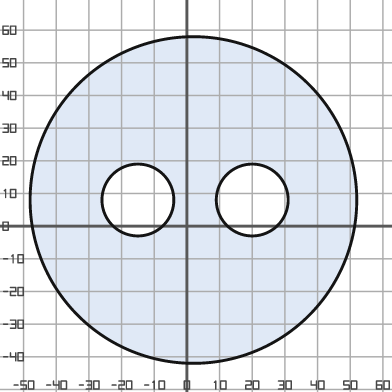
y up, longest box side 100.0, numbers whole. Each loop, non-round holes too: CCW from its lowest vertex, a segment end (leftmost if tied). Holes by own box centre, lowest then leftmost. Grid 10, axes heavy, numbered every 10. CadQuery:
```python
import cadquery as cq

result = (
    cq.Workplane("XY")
    .moveTo(2.0, 8.0)
    .circle(50.0)
    .moveTo(-15.0, 8.0)
    .circle(11.0)
    .moveTo(20.0, 8.0)
    .circle(11.0)
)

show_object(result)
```